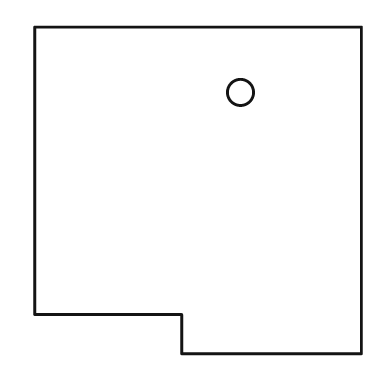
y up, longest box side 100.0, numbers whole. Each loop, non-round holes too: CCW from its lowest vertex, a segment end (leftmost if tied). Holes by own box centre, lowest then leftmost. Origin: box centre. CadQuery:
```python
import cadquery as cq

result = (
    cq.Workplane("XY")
    .moveTo(-5.0, -50.0)
    .lineTo(50.0, -50.0)
    .lineTo(50.0, 50.0)
    .lineTo(-50.0, 50.0)
    .lineTo(-50.0, -38.0)
    .lineTo(-5.0, -38.0)
    .close()
    .moveTo(13.0, 30.0)
    .circle(4.0)
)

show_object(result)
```